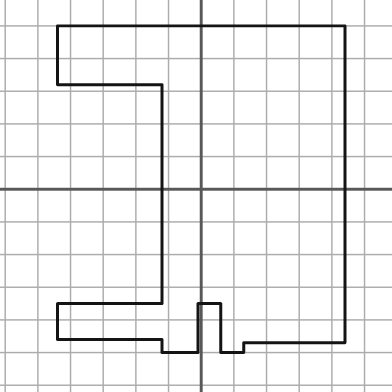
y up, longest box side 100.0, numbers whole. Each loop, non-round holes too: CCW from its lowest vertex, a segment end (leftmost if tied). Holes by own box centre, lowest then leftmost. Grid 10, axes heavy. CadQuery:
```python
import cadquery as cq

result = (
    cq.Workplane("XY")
    .moveTo(-12.0, -50.0)
    .lineTo(-1.0, -50.0)
    .lineTo(-1.0, -35.0)
    .lineTo(6.0, -35.0)
    .lineTo(6.0, -50.0)
    .lineTo(13.0, -50.0)
    .lineTo(13.0, -47.0)
    .lineTo(44.0, -47.0)
    .lineTo(44.0, 50.0)
    .lineTo(-44.0, 50.0)
    .lineTo(-44.0, 32.0)
    .lineTo(-12.0, 32.0)
    .lineTo(-12.0, -35.0)
    .lineTo(-44.0, -35.0)
    .lineTo(-44.0, -46.0)
    .lineTo(-12.0, -46.0)
    .close()
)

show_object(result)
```